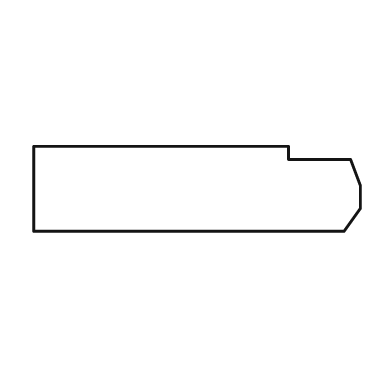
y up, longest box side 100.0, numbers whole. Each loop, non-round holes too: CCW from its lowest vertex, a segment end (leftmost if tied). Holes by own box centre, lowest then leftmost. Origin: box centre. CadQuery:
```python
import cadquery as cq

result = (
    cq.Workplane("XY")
    .moveTo(-50.0, -13.0)
    .lineTo(45.0, -13.0)
    .lineTo(50.0, -6.0)
    .lineTo(50.0, 1.0)
    .lineTo(47.0, 9.0)
    .lineTo(28.0, 9.0)
    .lineTo(28.0, 13.0)
    .lineTo(-50.0, 13.0)
    .close()
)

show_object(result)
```